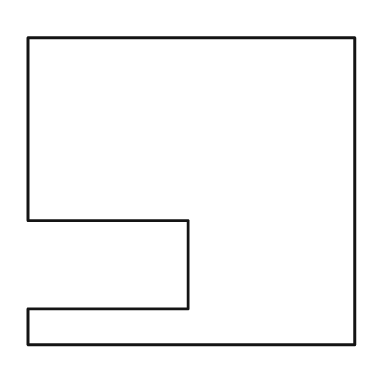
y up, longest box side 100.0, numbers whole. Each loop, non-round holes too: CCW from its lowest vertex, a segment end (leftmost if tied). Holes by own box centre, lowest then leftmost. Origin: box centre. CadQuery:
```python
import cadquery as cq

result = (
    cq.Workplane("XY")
    .moveTo(-50.0, -47.0)
    .lineTo(50.0, -47.0)
    .lineTo(50.0, 47.0)
    .lineTo(-50.0, 47.0)
    .lineTo(-50.0, -9.0)
    .lineTo(-1.0, -9.0)
    .lineTo(-1.0, -36.0)
    .lineTo(-50.0, -36.0)
    .close()
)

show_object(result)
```